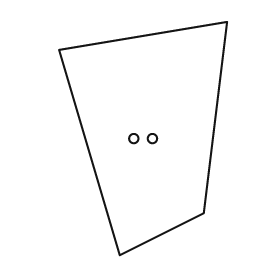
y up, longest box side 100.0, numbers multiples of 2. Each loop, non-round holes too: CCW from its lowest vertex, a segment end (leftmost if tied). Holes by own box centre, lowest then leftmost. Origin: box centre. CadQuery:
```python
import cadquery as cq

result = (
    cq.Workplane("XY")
    .moveTo(-10.0, -50.0)
    .lineTo(26.0, -32.0)
    .lineTo(36.0, 50.0)
    .lineTo(-36.0, 38.0)
    .close()
    .moveTo(-4.0, 0.0)
    .circle(2.0)
    .moveTo(4.0, 0.0)
    .circle(2.0)
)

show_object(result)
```